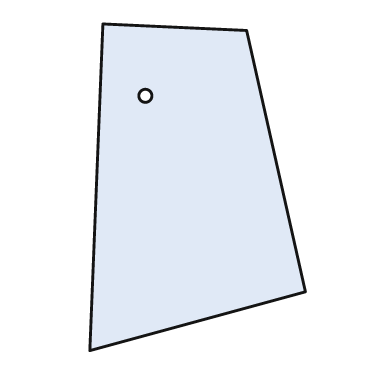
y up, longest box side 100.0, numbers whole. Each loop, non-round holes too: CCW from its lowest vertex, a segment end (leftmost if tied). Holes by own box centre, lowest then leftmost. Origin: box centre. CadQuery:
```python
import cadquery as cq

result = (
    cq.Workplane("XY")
    .moveTo(-33.0, -50.0)
    .lineTo(33.0, -32.0)
    .lineTo(15.0, 48.0)
    .lineTo(-29.0, 50.0)
    .close()
    .moveTo(-16.0, 28.0)
    .circle(2.0)
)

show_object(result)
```